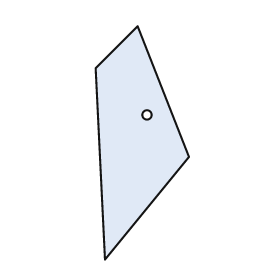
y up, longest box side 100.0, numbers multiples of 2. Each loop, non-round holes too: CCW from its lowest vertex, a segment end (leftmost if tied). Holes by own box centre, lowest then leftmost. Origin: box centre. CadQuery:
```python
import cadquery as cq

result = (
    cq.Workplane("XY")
    .moveTo(-16.0, -50.0)
    .lineTo(20.0, -6.0)
    .lineTo(-2.0, 50.0)
    .lineTo(-20.0, 32.0)
    .close()
    .moveTo(2.0, 12.0)
    .circle(2.0)
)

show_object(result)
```